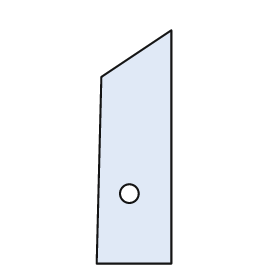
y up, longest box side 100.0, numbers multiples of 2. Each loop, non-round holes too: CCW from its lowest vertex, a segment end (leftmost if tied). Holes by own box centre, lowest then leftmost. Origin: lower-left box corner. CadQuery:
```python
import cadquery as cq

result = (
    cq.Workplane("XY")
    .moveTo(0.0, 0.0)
    .lineTo(32.0, 0.0)
    .lineTo(32.0, 100.0)
    .lineTo(2.0, 80.0)
    .close()
    .moveTo(14.0, 30.0)
    .circle(4.0)
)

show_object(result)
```